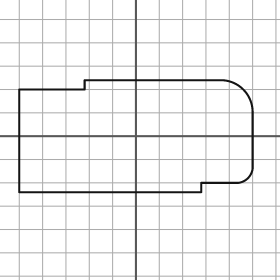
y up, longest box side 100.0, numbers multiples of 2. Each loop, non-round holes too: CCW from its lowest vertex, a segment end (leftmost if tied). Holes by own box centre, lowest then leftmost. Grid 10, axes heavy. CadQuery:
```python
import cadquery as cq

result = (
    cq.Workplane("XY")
    .moveTo(-50.0, -24.0)
    .lineTo(28.0, -24.0)
    .lineTo(28.0, -20.0)
    .lineTo(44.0, -20.0)
    .threePointArc((48.0, -18.0), (50.0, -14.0))
    .lineTo(50.0, 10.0)
    .threePointArc((46.0, 20.0), (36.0, 24.0))
    .lineTo(-22.0, 24.0)
    .lineTo(-22.0, 20.0)
    .lineTo(-50.0, 20.0)
    .close()
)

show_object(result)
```